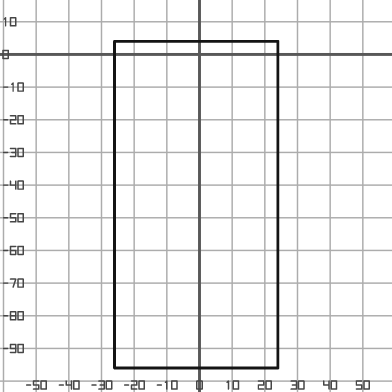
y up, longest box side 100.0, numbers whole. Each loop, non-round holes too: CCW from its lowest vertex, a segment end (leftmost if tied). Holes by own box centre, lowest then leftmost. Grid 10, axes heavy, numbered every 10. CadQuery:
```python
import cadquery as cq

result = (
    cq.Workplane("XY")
    .moveTo(-26.0, -96.0)
    .lineTo(24.0, -96.0)
    .lineTo(24.0, 4.0)
    .lineTo(-26.0, 4.0)
    .close()
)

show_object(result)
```